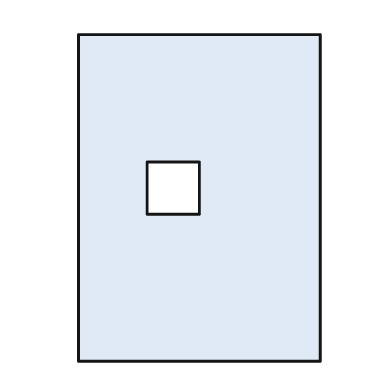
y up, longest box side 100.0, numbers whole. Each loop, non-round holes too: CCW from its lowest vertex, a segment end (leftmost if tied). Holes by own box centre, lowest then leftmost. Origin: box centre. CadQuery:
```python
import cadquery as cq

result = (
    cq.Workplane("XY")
    .moveTo(-37.0, -50.0)
    .lineTo(37.0, -50.0)
    .lineTo(37.0, 50.0)
    .lineTo(-37.0, 50.0)
    .close()
    .moveTo(-16.0, -5.0)
    .lineTo(0.0, -5.0)
    .lineTo(0.0, 11.0)
    .lineTo(-16.0, 11.0)
    .close()
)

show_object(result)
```